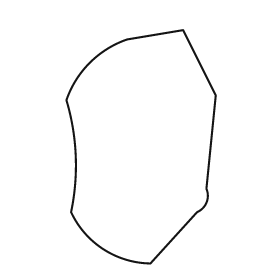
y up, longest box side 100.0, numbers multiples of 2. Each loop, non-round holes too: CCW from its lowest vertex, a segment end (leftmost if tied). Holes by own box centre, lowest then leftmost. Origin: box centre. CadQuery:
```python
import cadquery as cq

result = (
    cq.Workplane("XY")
    .moveTo(4.0, -50.0)
    .lineTo(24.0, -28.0)
    .threePointArc((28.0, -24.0), (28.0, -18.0))
    .lineTo(32.0, 22.0)
    .lineTo(18.0, 50.0)
    .lineTo(-6.0, 46.0)
    .threePointArc((-22.0, 36.0), (-32.0, 20.0))
    .threePointArc((-28.0, -4.0), (-30.0, -28.0))
    .threePointArc((-16.0, -44.0), (4.0, -50.0))
    .close()
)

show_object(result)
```